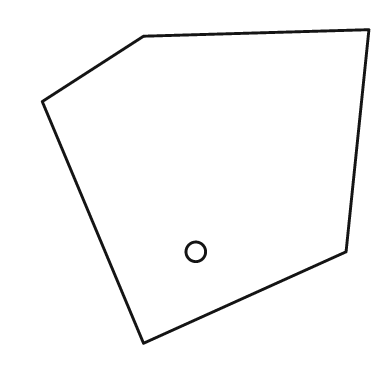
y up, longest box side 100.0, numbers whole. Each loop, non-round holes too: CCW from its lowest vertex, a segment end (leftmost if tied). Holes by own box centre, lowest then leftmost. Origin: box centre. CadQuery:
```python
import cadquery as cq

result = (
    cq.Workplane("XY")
    .moveTo(-19.0, -48.0)
    .lineTo(43.0, -20.0)
    .lineTo(50.0, 48.0)
    .lineTo(-19.0, 46.0)
    .lineTo(-50.0, 26.0)
    .close()
    .moveTo(-3.0, -20.0)
    .circle(3.0)
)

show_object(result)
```